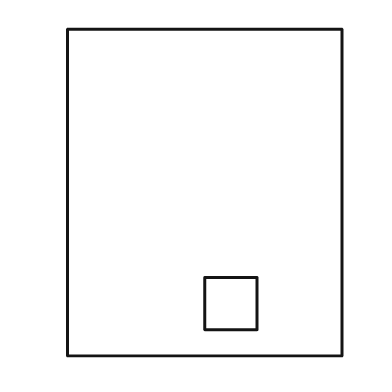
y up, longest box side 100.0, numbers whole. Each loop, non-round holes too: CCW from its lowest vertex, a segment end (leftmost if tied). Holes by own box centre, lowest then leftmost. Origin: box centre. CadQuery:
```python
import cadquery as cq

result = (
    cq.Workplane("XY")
    .moveTo(-42.0, -50.0)
    .lineTo(42.0, -50.0)
    .lineTo(42.0, 50.0)
    .lineTo(-42.0, 50.0)
    .close()
    .moveTo(0.0, -42.0)
    .lineTo(16.0, -42.0)
    .lineTo(16.0, -26.0)
    .lineTo(0.0, -26.0)
    .close()
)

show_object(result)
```